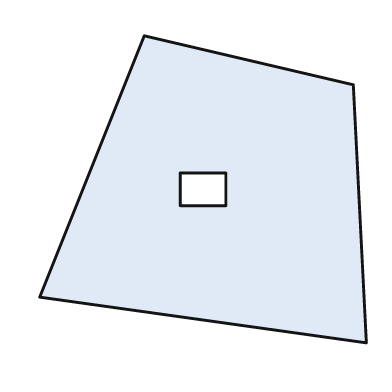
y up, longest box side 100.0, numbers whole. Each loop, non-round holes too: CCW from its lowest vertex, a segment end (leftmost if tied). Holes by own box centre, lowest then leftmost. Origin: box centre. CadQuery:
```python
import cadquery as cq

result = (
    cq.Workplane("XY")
    .moveTo(50.0, -47.0)
    .lineTo(46.0, 32.0)
    .lineTo(-18.0, 47.0)
    .lineTo(-50.0, -33.0)
    .close()
    .moveTo(-7.0, -5.0)
    .lineTo(7.0, -5.0)
    .lineTo(7.0, 5.0)
    .lineTo(-7.0, 5.0)
    .close()
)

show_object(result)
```